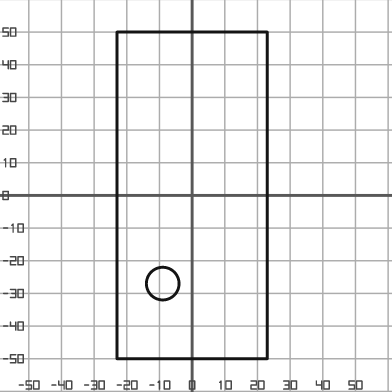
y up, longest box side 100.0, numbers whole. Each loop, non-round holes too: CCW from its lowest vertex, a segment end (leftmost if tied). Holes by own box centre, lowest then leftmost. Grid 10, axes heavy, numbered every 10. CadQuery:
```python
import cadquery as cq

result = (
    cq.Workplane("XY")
    .moveTo(-23.0, -50.0)
    .lineTo(23.0, -50.0)
    .lineTo(23.0, 50.0)
    .lineTo(-23.0, 50.0)
    .close()
    .moveTo(-9.0, -27.0)
    .circle(5.0)
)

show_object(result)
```